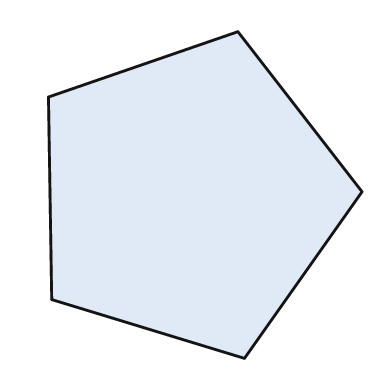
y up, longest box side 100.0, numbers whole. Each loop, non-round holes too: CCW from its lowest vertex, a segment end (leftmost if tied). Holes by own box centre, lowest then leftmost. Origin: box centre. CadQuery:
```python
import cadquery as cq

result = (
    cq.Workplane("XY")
    .moveTo(12.0, -50.0)
    .lineTo(48.0, 1.0)
    .lineTo(10.0, 50.0)
    .lineTo(-48.0, 30.0)
    .lineTo(-47.0, -32.0)
    .close()
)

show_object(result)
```